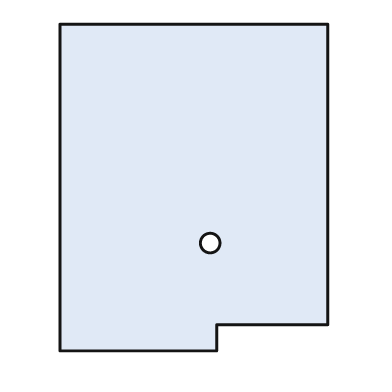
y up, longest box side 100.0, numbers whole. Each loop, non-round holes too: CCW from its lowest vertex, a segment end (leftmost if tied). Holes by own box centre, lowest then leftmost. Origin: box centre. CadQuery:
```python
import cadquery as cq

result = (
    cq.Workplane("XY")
    .moveTo(-41.0, -50.0)
    .lineTo(7.0, -50.0)
    .lineTo(7.0, -42.0)
    .lineTo(41.0, -42.0)
    .lineTo(41.0, 50.0)
    .lineTo(-41.0, 50.0)
    .close()
    .moveTo(5.0, -17.0)
    .circle(3.0)
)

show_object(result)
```